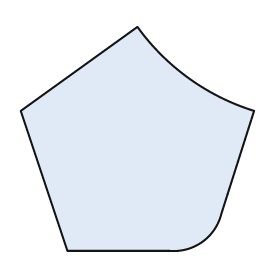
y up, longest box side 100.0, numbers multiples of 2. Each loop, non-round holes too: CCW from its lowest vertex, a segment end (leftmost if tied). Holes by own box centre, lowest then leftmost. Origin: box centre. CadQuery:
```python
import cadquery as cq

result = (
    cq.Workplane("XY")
    .moveTo(-30.0, -48.0)
    .lineTo(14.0, -48.0)
    .threePointArc((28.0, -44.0), (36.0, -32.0))
    .lineTo(50.0, 12.0)
    .threePointArc((22.0, 26.0), (0.0, 48.0))
    .lineTo(-50.0, 12.0)
    .close()
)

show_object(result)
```